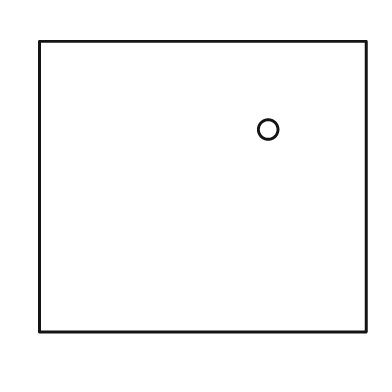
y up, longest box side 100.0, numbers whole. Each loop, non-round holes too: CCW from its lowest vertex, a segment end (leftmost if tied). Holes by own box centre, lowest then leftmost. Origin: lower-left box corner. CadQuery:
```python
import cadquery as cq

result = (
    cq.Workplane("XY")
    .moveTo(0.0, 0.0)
    .lineTo(100.0, 0.0)
    .lineTo(100.0, 89.0)
    .lineTo(0.0, 89.0)
    .close()
    .moveTo(70.0, 62.0)
    .circle(3.0)
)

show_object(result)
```